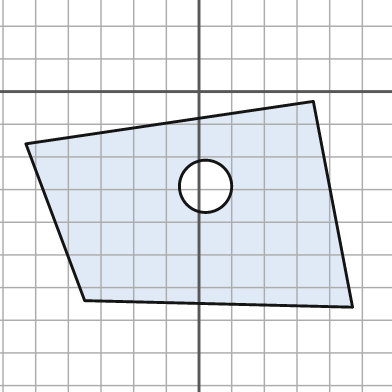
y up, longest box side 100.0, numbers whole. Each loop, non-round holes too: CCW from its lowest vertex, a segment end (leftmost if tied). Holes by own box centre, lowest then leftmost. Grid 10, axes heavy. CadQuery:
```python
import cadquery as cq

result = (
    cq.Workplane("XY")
    .moveTo(47.0, -66.0)
    .lineTo(35.0, -3.0)
    .lineTo(-53.0, -16.0)
    .lineTo(-35.0, -64.0)
    .close()
    .moveTo(2.0, -29.0)
    .circle(8.0)
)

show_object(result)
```